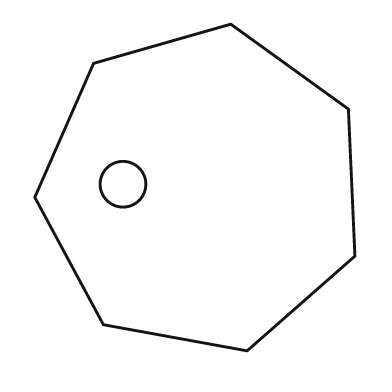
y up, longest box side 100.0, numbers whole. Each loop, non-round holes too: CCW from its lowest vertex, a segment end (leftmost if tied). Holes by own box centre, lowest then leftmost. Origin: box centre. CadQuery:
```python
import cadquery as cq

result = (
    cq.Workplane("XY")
    .moveTo(16.0, -50.0)
    .lineTo(49.0, -21.0)
    .lineTo(47.0, 24.0)
    .lineTo(11.0, 50.0)
    .lineTo(-31.0, 38.0)
    .lineTo(-49.0, -3.0)
    .lineTo(-28.0, -42.0)
    .close()
    .moveTo(-22.0, 1.0)
    .circle(7.0)
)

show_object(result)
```